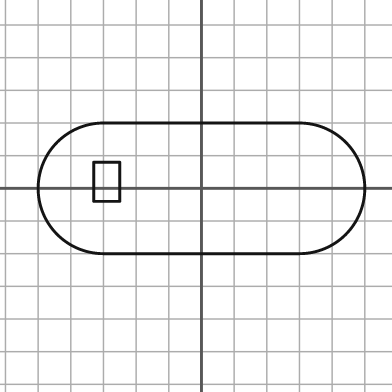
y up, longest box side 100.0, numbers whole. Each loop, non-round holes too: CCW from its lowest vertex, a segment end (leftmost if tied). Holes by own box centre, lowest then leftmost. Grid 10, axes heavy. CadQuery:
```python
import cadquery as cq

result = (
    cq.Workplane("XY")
    .moveTo(-30.0, -20.0)
    .lineTo(30.0, -20.0)
    .threePointArc((50.0, 0.0), (30.0, 20.0))
    .lineTo(-30.0, 20.0)
    .threePointArc((-50.0, 0.0), (-30.0, -20.0))
    .close()
    .moveTo(-33.0, -4.0)
    .lineTo(-25.0, -4.0)
    .lineTo(-25.0, 8.0)
    .lineTo(-33.0, 8.0)
    .close()
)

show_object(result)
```